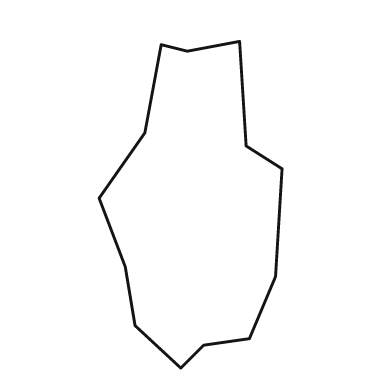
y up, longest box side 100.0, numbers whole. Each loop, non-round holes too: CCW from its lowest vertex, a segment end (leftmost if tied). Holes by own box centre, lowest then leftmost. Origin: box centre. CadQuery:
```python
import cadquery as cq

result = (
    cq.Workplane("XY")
    .moveTo(-3.0, -50.0)
    .lineTo(4.0, -43.0)
    .lineTo(18.0, -41.0)
    .lineTo(26.0, -22.0)
    .lineTo(28.0, 11.0)
    .lineTo(17.0, 18.0)
    .lineTo(15.0, 50.0)
    .lineTo(-1.0, 47.0)
    .lineTo(-9.0, 49.0)
    .lineTo(-14.0, 22.0)
    .lineTo(-28.0, 2.0)
    .lineTo(-20.0, -19.0)
    .lineTo(-17.0, -37.0)
    .close()
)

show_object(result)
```